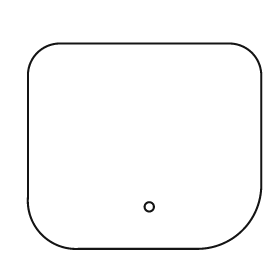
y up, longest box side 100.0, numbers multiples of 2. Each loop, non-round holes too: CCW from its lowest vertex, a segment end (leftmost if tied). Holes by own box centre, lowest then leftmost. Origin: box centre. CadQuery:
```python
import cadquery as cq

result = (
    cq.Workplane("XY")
    .moveTo(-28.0, -44.0)
    .lineTo(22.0, -44.0)
    .threePointArc((42.0, -36.0), (50.0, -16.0))
    .lineTo(50.0, 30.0)
    .threePointArc((46.0, 40.0), (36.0, 44.0))
    .lineTo(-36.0, 44.0)
    .threePointArc((-46.0, 40.0), (-50.0, 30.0))
    .lineTo(-50.0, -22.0)
    .threePointArc((-44.0, -38.0), (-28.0, -44.0))
    .close()
    .moveTo(2.0, -26.0)
    .circle(2.0)
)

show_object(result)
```